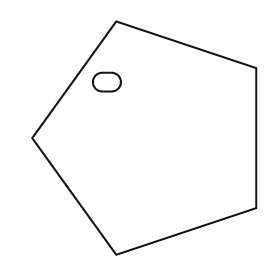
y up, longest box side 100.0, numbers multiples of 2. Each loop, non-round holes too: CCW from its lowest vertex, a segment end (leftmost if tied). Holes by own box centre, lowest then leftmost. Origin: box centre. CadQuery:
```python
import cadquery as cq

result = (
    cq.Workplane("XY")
    .moveTo(-12.0, -50.0)
    .lineTo(48.0, -30.0)
    .lineTo(48.0, 30.0)
    .lineTo(-12.0, 50.0)
    .lineTo(-48.0, 0.0)
    .close()
    .moveTo(-18.0, 20.0)
    .lineTo(-14.0, 20.0)
    .threePointArc((-10.0, 24.0), (-14.0, 28.0))
    .lineTo(-18.0, 28.0)
    .threePointArc((-22.0, 24.0), (-18.0, 20.0))
    .close()
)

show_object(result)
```